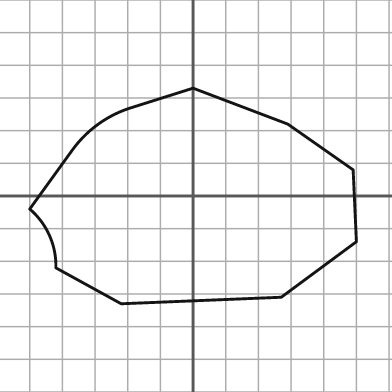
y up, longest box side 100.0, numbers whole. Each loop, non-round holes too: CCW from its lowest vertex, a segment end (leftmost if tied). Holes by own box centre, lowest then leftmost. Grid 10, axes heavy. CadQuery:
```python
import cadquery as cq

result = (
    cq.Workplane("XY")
    .moveTo(-22.0, -33.0)
    .lineTo(27.0, -31.0)
    .lineTo(50.0, -14.0)
    .lineTo(49.0, 8.0)
    .lineTo(29.0, 22.0)
    .lineTo(0.0, 33.0)
    .lineTo(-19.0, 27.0)
    .threePointArc((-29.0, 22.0), (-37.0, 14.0))
    .lineTo(-50.0, -4.0)
    .threePointArc((-44.0, -12.0), (-42.0, -22.0))
    .close()
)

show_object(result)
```